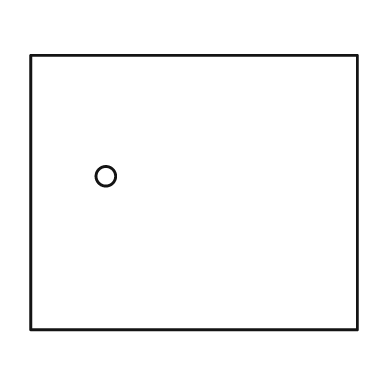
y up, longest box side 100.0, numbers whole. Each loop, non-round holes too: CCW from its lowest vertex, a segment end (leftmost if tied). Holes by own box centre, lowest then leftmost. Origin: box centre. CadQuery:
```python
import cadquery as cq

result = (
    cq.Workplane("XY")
    .moveTo(-50.0, -42.0)
    .lineTo(50.0, -42.0)
    .lineTo(50.0, 42.0)
    .lineTo(-50.0, 42.0)
    .close()
    .moveTo(-27.0, 5.0)
    .circle(3.0)
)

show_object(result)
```